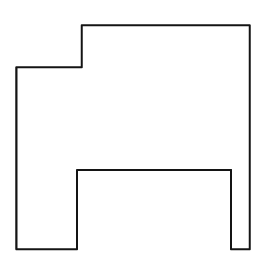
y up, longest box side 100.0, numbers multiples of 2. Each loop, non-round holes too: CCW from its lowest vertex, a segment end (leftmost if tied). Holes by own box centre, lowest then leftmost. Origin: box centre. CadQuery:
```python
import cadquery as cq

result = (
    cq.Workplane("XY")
    .moveTo(-50.0, -48.0)
    .lineTo(-24.0, -48.0)
    .lineTo(-24.0, -14.0)
    .lineTo(42.0, -14.0)
    .lineTo(42.0, -48.0)
    .lineTo(50.0, -48.0)
    .lineTo(50.0, 48.0)
    .lineTo(-22.0, 48.0)
    .lineTo(-22.0, 30.0)
    .lineTo(-50.0, 30.0)
    .close()
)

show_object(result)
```